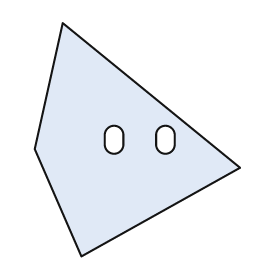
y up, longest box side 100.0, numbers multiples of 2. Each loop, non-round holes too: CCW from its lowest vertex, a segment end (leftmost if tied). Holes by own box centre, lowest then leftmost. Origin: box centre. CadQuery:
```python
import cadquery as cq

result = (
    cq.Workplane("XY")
    .moveTo(-24.0, -50.0)
    .lineTo(44.0, -12.0)
    .lineTo(-32.0, 50.0)
    .lineTo(-44.0, -4.0)
    .close()
    .moveTo(-14.0, -2.0)
    .threePointArc((-10.0, -6.0), (-6.0, -2.0))
    .lineTo(-6.0, 2.0)
    .threePointArc((-10.0, 6.0), (-14.0, 2.0))
    .close()
    .moveTo(8.0, -2.0)
    .threePointArc((12.0, -6.0), (16.0, -2.0))
    .lineTo(16.0, 2.0)
    .threePointArc((12.0, 6.0), (8.0, 2.0))
    .close()
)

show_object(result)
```